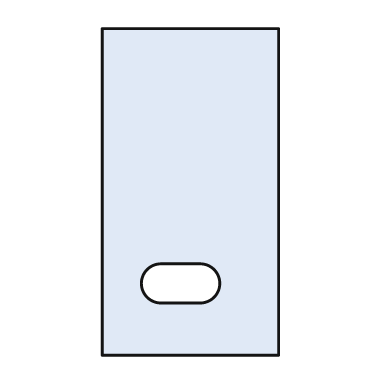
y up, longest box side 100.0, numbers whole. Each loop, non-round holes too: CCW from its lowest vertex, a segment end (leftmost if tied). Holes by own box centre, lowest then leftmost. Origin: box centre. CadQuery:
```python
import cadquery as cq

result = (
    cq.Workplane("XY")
    .moveTo(-27.0, -50.0)
    .lineTo(27.0, -50.0)
    .lineTo(27.0, 50.0)
    .lineTo(-27.0, 50.0)
    .close()
    .moveTo(-9.0, -34.0)
    .lineTo(3.0, -34.0)
    .threePointArc((9.0, -28.0), (3.0, -22.0))
    .lineTo(-9.0, -22.0)
    .threePointArc((-15.0, -28.0), (-9.0, -34.0))
    .close()
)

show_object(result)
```